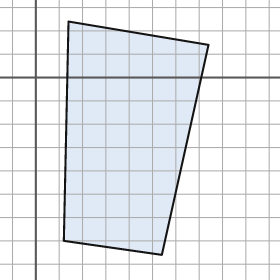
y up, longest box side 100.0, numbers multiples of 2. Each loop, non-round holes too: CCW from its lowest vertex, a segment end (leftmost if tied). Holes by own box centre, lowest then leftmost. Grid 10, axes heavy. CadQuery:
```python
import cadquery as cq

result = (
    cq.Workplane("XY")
    .moveTo(54.0, -76.0)
    .lineTo(74.0, 14.0)
    .lineTo(14.0, 24.0)
    .lineTo(12.0, -70.0)
    .close()
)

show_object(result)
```